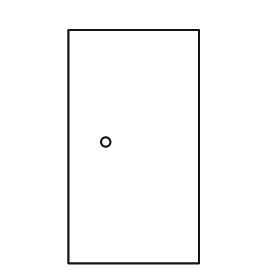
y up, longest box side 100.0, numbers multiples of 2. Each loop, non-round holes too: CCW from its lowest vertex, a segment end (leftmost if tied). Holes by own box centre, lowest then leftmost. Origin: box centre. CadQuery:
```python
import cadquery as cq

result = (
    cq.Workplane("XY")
    .moveTo(-28.0, -50.0)
    .lineTo(28.0, -50.0)
    .lineTo(28.0, 50.0)
    .lineTo(-28.0, 50.0)
    .close()
    .moveTo(-12.0, 2.0)
    .circle(2.0)
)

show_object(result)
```